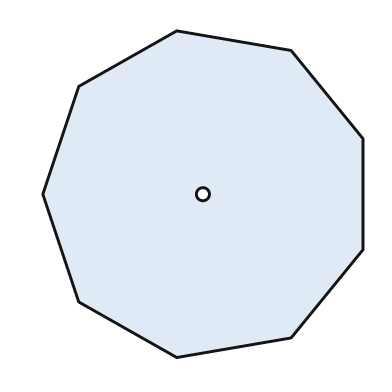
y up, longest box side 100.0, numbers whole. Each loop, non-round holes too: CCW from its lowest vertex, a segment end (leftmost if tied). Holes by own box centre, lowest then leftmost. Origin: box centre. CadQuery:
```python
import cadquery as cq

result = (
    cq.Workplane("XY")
    .moveTo(-8.0, -50.0)
    .lineTo(27.0, -44.0)
    .lineTo(49.0, -17.0)
    .lineTo(49.0, 17.0)
    .lineTo(27.0, 44.0)
    .lineTo(-8.0, 50.0)
    .lineTo(-38.0, 33.0)
    .lineTo(-49.0, 0.0)
    .lineTo(-38.0, -33.0)
    .close()
    .moveTo(0.0, 0.0)
    .circle(2.0)
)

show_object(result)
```